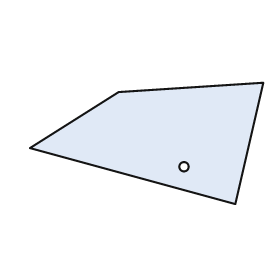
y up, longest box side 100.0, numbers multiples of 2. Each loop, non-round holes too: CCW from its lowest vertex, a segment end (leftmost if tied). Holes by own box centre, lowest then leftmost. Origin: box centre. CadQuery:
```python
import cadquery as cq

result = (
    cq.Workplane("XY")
    .moveTo(38.0, -26.0)
    .lineTo(50.0, 26.0)
    .lineTo(-12.0, 22.0)
    .lineTo(-50.0, -2.0)
    .close()
    .moveTo(16.0, -10.0)
    .circle(2.0)
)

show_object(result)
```